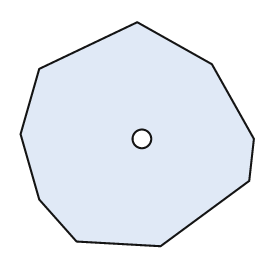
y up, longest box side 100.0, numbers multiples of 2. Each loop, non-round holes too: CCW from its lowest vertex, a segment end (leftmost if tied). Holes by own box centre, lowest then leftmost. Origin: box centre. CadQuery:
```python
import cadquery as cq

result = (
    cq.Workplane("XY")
    .moveTo(10.0, -48.0)
    .lineTo(48.0, -20.0)
    .lineTo(50.0, -2.0)
    .lineTo(32.0, 30.0)
    .lineTo(0.0, 48.0)
    .lineTo(-42.0, 28.0)
    .lineTo(-50.0, 0.0)
    .lineTo(-42.0, -28.0)
    .lineTo(-26.0, -46.0)
    .close()
    .moveTo(2.0, -2.0)
    .circle(4.0)
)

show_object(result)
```